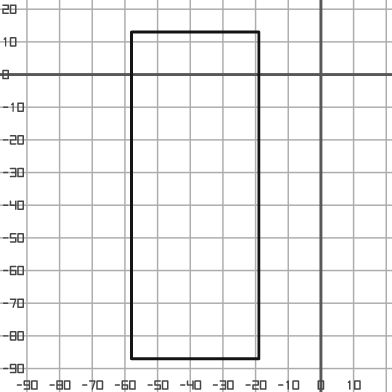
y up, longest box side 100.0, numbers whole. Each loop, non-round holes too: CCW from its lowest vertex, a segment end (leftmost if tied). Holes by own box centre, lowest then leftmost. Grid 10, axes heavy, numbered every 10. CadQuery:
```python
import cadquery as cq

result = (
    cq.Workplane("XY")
    .moveTo(-58.0, -87.0)
    .lineTo(-19.0, -87.0)
    .lineTo(-19.0, 13.0)
    .lineTo(-58.0, 13.0)
    .close()
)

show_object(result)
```